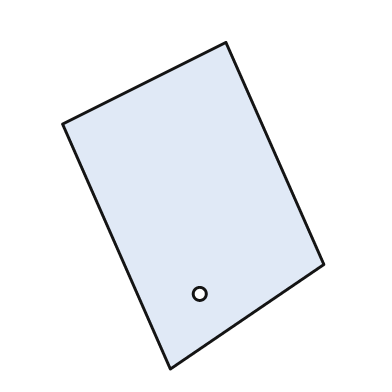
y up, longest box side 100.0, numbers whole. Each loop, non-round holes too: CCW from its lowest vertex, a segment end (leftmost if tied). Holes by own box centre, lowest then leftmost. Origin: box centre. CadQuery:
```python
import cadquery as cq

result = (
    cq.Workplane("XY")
    .moveTo(-7.0, -50.0)
    .lineTo(40.0, -18.0)
    .lineTo(10.0, 50.0)
    .lineTo(-40.0, 25.0)
    .close()
    .moveTo(2.0, -27.0)
    .circle(2.0)
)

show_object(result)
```